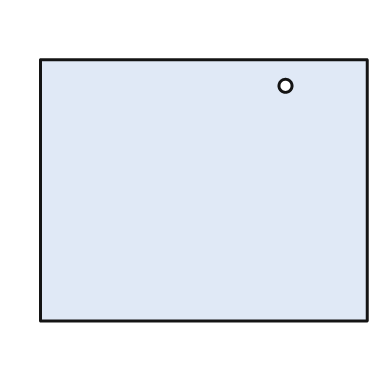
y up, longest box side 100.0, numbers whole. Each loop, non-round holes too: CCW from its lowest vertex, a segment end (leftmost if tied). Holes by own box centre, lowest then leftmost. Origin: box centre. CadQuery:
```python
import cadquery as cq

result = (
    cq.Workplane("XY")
    .moveTo(-50.0, -40.0)
    .lineTo(50.0, -40.0)
    .lineTo(50.0, 40.0)
    .lineTo(-50.0, 40.0)
    .close()
    .moveTo(25.0, 32.0)
    .circle(2.0)
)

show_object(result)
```